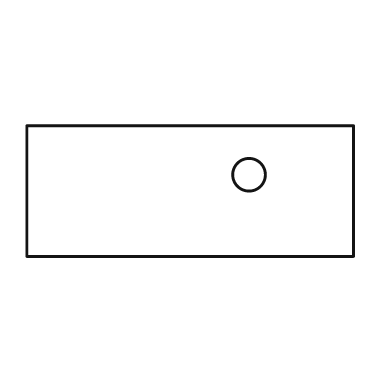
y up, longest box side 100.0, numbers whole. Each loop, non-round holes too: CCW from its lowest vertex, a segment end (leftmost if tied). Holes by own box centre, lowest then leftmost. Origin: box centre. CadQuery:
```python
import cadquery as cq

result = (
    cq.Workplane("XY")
    .moveTo(-50.0, -20.0)
    .lineTo(50.0, -20.0)
    .lineTo(50.0, 20.0)
    .lineTo(-50.0, 20.0)
    .close()
    .moveTo(18.0, 5.0)
    .circle(5.0)
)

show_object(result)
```